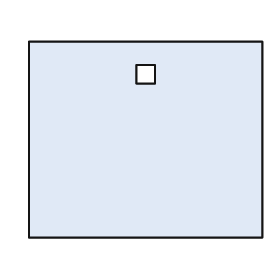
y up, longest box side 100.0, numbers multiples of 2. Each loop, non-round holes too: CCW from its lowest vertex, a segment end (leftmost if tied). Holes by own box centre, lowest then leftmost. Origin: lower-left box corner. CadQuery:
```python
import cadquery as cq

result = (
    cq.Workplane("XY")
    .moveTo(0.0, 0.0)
    .lineTo(100.0, 0.0)
    .lineTo(100.0, 84.0)
    .lineTo(0.0, 84.0)
    .close()
    .moveTo(46.0, 66.0)
    .lineTo(54.0, 66.0)
    .lineTo(54.0, 74.0)
    .lineTo(46.0, 74.0)
    .close()
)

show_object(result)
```